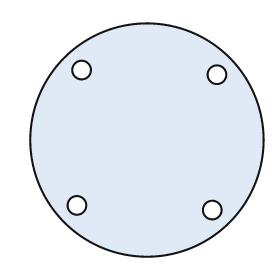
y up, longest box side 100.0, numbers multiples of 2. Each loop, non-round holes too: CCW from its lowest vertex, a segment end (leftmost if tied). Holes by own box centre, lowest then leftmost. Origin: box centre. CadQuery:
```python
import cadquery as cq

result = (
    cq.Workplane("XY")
    .moveTo(0.0, 0.0)
    .circle(50.0)
    .moveTo(28.0, -30.0)
    .circle(4.0)
    .moveTo(-30.0, -28.0)
    .circle(4.0)
    .moveTo(30.0, 28.0)
    .circle(4.0)
    .moveTo(-28.0, 30.0)
    .circle(4.0)
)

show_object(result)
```